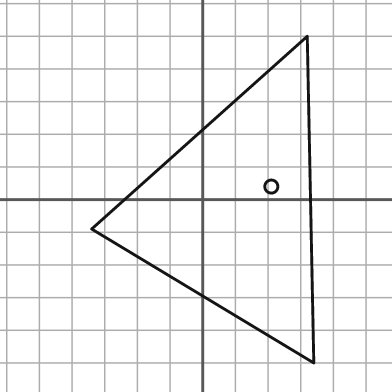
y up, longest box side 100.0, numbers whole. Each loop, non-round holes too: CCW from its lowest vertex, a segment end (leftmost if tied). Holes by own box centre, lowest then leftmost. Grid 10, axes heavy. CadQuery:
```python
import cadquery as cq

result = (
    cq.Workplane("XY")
    .moveTo(34.0, -50.0)
    .lineTo(32.0, 50.0)
    .lineTo(-34.0, -9.0)
    .close()
    .moveTo(21.0, 4.0)
    .circle(2.0)
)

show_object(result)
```